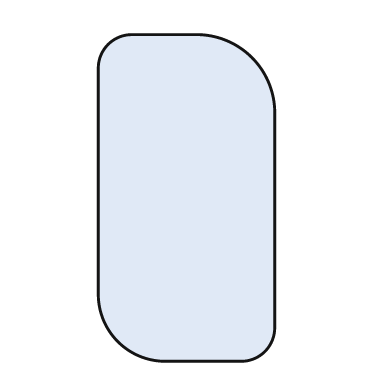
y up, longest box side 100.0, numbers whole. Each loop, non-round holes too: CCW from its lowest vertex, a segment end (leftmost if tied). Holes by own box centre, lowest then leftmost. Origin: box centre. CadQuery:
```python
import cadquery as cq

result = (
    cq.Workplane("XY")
    .moveTo(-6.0, -50.0)
    .lineTo(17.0, -50.0)
    .threePointArc((24.0, -47.0), (27.0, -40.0))
    .lineTo(27.0, 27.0)
    .threePointArc((20.0, 43.0), (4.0, 50.0))
    .lineTo(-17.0, 50.0)
    .threePointArc((-24.0, 47.0), (-27.0, 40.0))
    .lineTo(-27.0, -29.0)
    .threePointArc((-21.0, -44.0), (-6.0, -50.0))
    .close()
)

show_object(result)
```